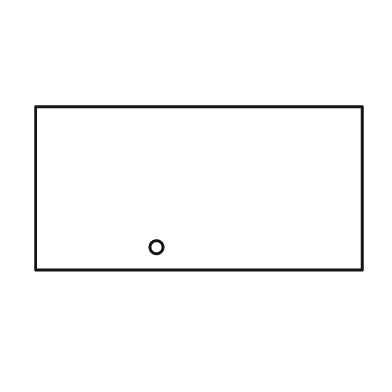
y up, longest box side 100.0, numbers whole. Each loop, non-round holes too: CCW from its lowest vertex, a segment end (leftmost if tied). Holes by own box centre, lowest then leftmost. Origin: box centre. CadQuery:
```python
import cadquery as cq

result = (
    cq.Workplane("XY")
    .moveTo(-50.0, -25.0)
    .lineTo(50.0, -25.0)
    .lineTo(50.0, 25.0)
    .lineTo(-50.0, 25.0)
    .close()
    .moveTo(-13.0, -18.0)
    .circle(2.0)
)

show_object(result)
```